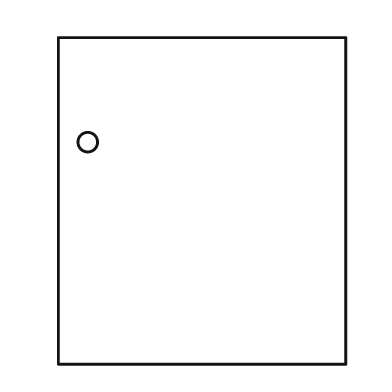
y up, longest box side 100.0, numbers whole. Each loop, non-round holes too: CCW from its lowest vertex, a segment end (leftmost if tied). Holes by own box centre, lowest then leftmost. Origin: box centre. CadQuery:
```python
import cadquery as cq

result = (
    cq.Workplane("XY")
    .moveTo(-44.0, -50.0)
    .lineTo(44.0, -50.0)
    .lineTo(44.0, 50.0)
    .lineTo(-44.0, 50.0)
    .close()
    .moveTo(-35.0, 18.0)
    .circle(3.0)
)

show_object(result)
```